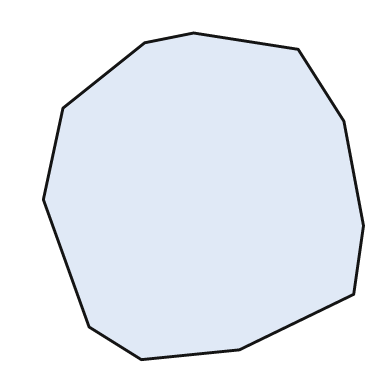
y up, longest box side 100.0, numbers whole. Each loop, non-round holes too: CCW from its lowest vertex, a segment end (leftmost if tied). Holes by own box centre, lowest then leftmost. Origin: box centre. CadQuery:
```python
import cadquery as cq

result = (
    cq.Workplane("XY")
    .moveTo(-19.0, -50.0)
    .lineTo(11.0, -47.0)
    .lineTo(46.0, -30.0)
    .lineTo(49.0, -9.0)
    .lineTo(43.0, 23.0)
    .lineTo(29.0, 45.0)
    .lineTo(-3.0, 50.0)
    .lineTo(-18.0, 47.0)
    .lineTo(-43.0, 27.0)
    .lineTo(-49.0, -1.0)
    .lineTo(-35.0, -40.0)
    .close()
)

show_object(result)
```